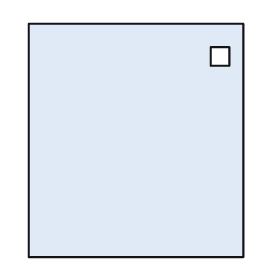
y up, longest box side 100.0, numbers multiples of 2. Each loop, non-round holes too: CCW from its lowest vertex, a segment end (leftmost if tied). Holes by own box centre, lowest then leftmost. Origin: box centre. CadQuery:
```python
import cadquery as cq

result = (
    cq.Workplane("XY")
    .moveTo(-46.0, -50.0)
    .lineTo(46.0, -50.0)
    .lineTo(46.0, 50.0)
    .lineTo(-46.0, 50.0)
    .close()
    .moveTo(32.0, 32.0)
    .lineTo(40.0, 32.0)
    .lineTo(40.0, 40.0)
    .lineTo(32.0, 40.0)
    .close()
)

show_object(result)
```